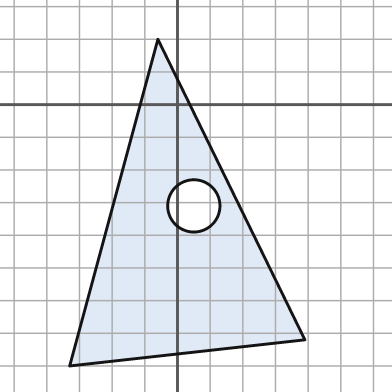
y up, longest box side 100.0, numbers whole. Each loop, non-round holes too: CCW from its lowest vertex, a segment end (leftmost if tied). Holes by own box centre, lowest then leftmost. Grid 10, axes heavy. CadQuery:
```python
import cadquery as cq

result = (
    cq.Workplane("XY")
    .moveTo(-33.0, -80.0)
    .lineTo(39.0, -72.0)
    .lineTo(-6.0, 20.0)
    .close()
    .moveTo(5.0, -31.0)
    .circle(8.0)
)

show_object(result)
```